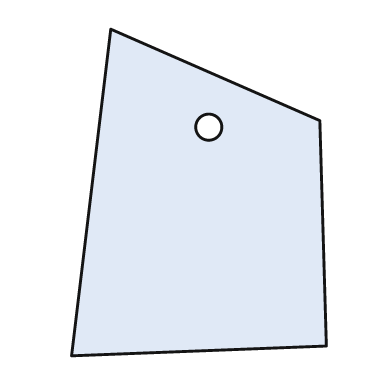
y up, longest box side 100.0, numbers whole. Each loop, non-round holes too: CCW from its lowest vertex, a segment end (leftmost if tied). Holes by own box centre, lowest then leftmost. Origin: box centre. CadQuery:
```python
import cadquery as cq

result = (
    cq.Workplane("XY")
    .moveTo(-39.0, -50.0)
    .lineTo(39.0, -47.0)
    .lineTo(37.0, 22.0)
    .lineTo(-27.0, 50.0)
    .close()
    .moveTo(3.0, 20.0)
    .circle(4.0)
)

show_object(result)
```